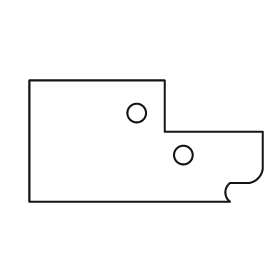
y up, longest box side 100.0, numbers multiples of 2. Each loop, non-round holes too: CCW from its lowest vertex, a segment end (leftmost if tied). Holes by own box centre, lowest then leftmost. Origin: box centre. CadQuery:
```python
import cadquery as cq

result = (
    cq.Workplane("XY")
    .moveTo(-50.0, -26.0)
    .lineTo(36.0, -26.0)
    .threePointArc((34.0, -22.0), (36.0, -18.0))
    .lineTo(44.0, -18.0)
    .threePointArc((48.0, -16.0), (50.0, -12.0))
    .lineTo(50.0, 4.0)
    .lineTo(8.0, 4.0)
    .lineTo(8.0, 26.0)
    .lineTo(-50.0, 26.0)
    .close()
    .moveTo(16.0, -6.0)
    .circle(4.0)
    .moveTo(-4.0, 12.0)
    .circle(4.0)
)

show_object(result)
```